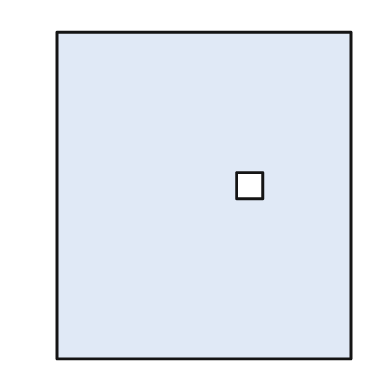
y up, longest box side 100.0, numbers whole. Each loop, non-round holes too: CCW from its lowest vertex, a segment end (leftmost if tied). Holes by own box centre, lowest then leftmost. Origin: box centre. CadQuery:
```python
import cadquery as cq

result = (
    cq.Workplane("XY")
    .moveTo(-45.0, -50.0)
    .lineTo(45.0, -50.0)
    .lineTo(45.0, 50.0)
    .lineTo(-45.0, 50.0)
    .close()
    .moveTo(10.0, -1.0)
    .lineTo(18.0, -1.0)
    .lineTo(18.0, 7.0)
    .lineTo(10.0, 7.0)
    .close()
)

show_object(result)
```